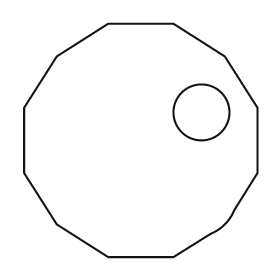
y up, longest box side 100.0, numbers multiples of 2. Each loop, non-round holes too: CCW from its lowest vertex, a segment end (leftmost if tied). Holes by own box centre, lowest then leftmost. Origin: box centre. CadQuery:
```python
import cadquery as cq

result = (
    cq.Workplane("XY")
    .moveTo(-14.0, -50.0)
    .lineTo(14.0, -50.0)
    .lineTo(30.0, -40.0)
    .threePointArc((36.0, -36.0), (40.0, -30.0))
    .lineTo(50.0, -14.0)
    .lineTo(50.0, 14.0)
    .lineTo(36.0, 36.0)
    .lineTo(14.0, 50.0)
    .lineTo(-14.0, 50.0)
    .lineTo(-36.0, 36.0)
    .lineTo(-50.0, 14.0)
    .lineTo(-50.0, -14.0)
    .lineTo(-36.0, -36.0)
    .close()
    .moveTo(26.0, 12.0)
    .circle(12.0)
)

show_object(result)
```